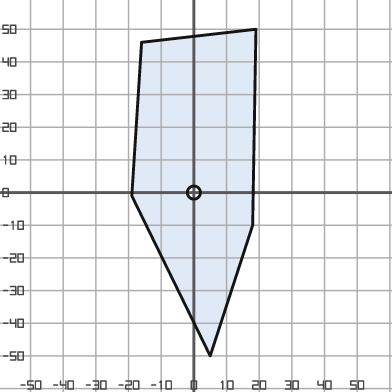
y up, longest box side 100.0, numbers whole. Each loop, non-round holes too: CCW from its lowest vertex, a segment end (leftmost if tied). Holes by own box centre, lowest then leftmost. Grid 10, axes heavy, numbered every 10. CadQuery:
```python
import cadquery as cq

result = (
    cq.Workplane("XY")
    .moveTo(5.0, -50.0)
    .lineTo(18.0, -10.0)
    .lineTo(19.0, 50.0)
    .lineTo(-16.0, 46.0)
    .lineTo(-19.0, -1.0)
    .close()
    .moveTo(0.0, 0.0)
    .circle(2.0)
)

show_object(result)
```